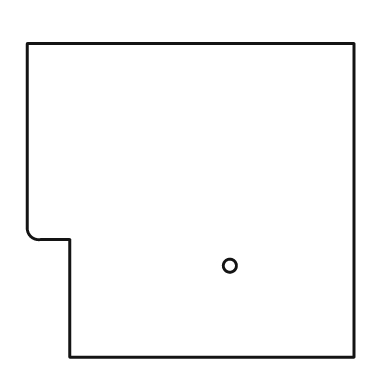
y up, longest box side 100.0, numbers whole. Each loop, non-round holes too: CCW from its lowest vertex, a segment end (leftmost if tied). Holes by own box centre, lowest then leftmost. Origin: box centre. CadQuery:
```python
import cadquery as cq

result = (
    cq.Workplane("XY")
    .moveTo(-37.0, -48.0)
    .lineTo(50.0, -48.0)
    .lineTo(50.0, 48.0)
    .lineTo(-50.0, 48.0)
    .lineTo(-50.0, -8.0)
    .threePointArc((-49.0, -11.0), (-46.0, -12.0))
    .lineTo(-37.0, -12.0)
    .close()
    .moveTo(12.0, -20.0)
    .circle(2.0)
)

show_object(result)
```